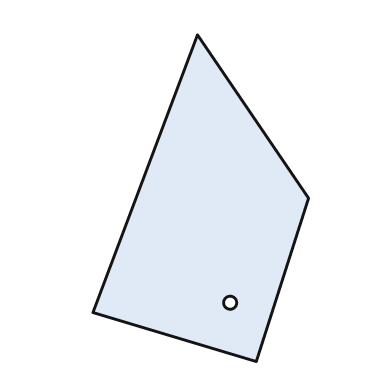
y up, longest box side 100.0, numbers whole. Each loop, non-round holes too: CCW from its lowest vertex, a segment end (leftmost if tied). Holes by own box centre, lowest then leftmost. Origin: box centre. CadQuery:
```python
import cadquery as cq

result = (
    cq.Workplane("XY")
    .moveTo(17.0, -50.0)
    .lineTo(33.0, 0.0)
    .lineTo(-1.0, 50.0)
    .lineTo(-33.0, -35.0)
    .close()
    .moveTo(9.0, -32.0)
    .circle(2.0)
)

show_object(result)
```